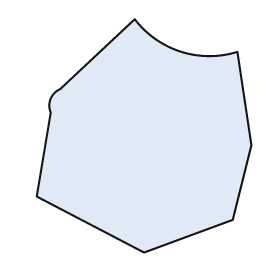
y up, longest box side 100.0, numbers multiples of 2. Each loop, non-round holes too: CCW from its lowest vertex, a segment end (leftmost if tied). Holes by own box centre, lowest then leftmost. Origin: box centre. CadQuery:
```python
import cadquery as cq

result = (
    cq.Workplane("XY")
    .moveTo(0.0, -50.0)
    .lineTo(38.0, -36.0)
    .lineTo(46.0, -4.0)
    .lineTo(40.0, 36.0)
    .threePointArc((16.0, 36.0), (-4.0, 50.0))
    .lineTo(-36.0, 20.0)
    .threePointArc((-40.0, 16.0), (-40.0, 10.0))
    .lineTo(-46.0, -26.0)
    .close()
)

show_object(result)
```